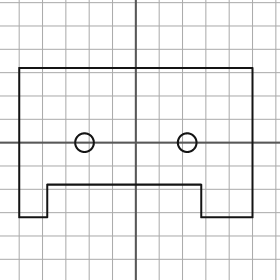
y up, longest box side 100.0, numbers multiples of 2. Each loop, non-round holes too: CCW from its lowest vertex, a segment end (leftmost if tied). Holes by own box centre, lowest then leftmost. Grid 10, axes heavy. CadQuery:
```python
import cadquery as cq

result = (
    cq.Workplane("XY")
    .moveTo(-50.0, -32.0)
    .lineTo(-38.0, -32.0)
    .lineTo(-38.0, -18.0)
    .lineTo(28.0, -18.0)
    .lineTo(28.0, -32.0)
    .lineTo(50.0, -32.0)
    .lineTo(50.0, 32.0)
    .lineTo(-50.0, 32.0)
    .close()
    .moveTo(-22.0, 0.0)
    .circle(4.0)
    .moveTo(22.0, 0.0)
    .circle(4.0)
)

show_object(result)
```